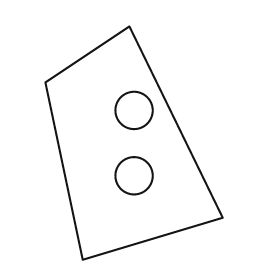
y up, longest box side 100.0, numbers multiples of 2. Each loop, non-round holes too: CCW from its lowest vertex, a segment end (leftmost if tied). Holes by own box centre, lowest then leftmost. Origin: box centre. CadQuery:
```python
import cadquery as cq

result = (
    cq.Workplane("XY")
    .moveTo(-22.0, -50.0)
    .lineTo(38.0, -32.0)
    .lineTo(-2.0, 50.0)
    .lineTo(-38.0, 26.0)
    .close()
    .moveTo(0.0, -14.0)
    .circle(8.0)
    .moveTo(0.0, 14.0)
    .circle(8.0)
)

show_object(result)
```